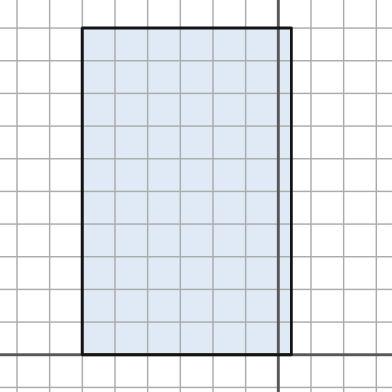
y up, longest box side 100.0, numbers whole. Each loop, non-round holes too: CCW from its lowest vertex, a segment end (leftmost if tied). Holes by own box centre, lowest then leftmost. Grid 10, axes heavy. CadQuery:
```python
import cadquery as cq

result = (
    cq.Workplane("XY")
    .moveTo(-60.0, 0.0)
    .lineTo(4.0, 0.0)
    .lineTo(4.0, 100.0)
    .lineTo(-60.0, 100.0)
    .close()
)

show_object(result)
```